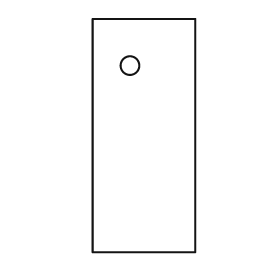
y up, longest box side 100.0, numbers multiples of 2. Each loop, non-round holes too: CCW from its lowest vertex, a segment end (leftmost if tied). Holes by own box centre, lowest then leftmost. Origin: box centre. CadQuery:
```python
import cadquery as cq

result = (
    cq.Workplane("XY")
    .moveTo(-22.0, -50.0)
    .lineTo(22.0, -50.0)
    .lineTo(22.0, 50.0)
    .lineTo(-22.0, 50.0)
    .close()
    .moveTo(-6.0, 30.0)
    .circle(4.0)
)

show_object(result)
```